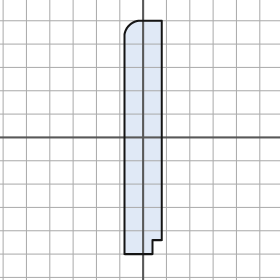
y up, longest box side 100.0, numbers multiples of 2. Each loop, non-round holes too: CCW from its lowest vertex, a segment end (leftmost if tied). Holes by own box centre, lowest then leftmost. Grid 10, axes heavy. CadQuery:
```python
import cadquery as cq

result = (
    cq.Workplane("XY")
    .moveTo(-8.0, -50.0)
    .lineTo(4.0, -50.0)
    .lineTo(4.0, -44.0)
    .lineTo(8.0, -44.0)
    .lineTo(8.0, 50.0)
    .lineTo(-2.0, 50.0)
    .threePointArc((-6.0, 48.0), (-8.0, 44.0))
    .close()
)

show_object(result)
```